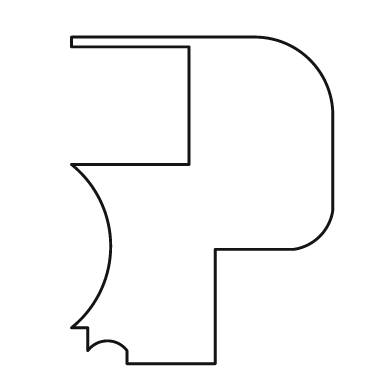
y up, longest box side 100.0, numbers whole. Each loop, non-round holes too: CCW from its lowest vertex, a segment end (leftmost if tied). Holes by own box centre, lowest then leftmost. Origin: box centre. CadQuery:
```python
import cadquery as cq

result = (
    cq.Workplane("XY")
    .moveTo(-23.0, -50.0)
    .lineTo(4.0, -50.0)
    .lineTo(4.0, -15.0)
    .lineTo(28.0, -15.0)
    .threePointArc((36.0, -11.0), (40.0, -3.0))
    .lineTo(40.0, 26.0)
    .threePointArc((33.0, 43.0), (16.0, 50.0))
    .lineTo(-40.0, 50.0)
    .lineTo(-40.0, 47.0)
    .lineTo(-4.0, 47.0)
    .lineTo(-4.0, 11.0)
    .lineTo(-40.0, 11.0)
    .threePointArc((-28.0, -14.0), (-40.0, -39.0))
    .lineTo(-35.0, -39.0)
    .lineTo(-35.0, -46.0)
    .threePointArc((-29.0, -43.0), (-23.0, -46.0))
    .close()
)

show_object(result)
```